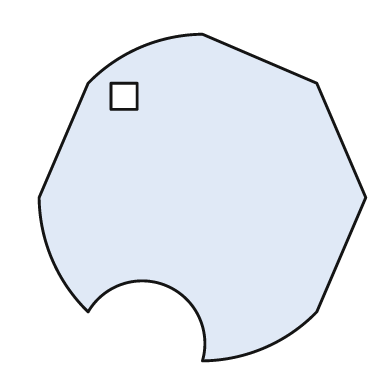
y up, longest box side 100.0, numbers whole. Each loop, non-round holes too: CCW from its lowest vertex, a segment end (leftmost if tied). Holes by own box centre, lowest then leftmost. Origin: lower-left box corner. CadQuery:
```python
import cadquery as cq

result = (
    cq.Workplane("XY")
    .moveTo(50.0, 0.0)
    .threePointArc((69.0, 4.0), (85.0, 15.0))
    .lineTo(100.0, 50.0)
    .lineTo(85.0, 85.0)
    .lineTo(50.0, 100.0)
    .threePointArc((31.0, 96.0), (15.0, 85.0))
    .lineTo(0.0, 50.0)
    .threePointArc((4.0, 31.0), (15.0, 15.0))
    .threePointArc((39.0, 23.0), (50.0, 0.0))
    .close()
    .moveTo(22.0, 77.0)
    .lineTo(30.0, 77.0)
    .lineTo(30.0, 85.0)
    .lineTo(22.0, 85.0)
    .close()
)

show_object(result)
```